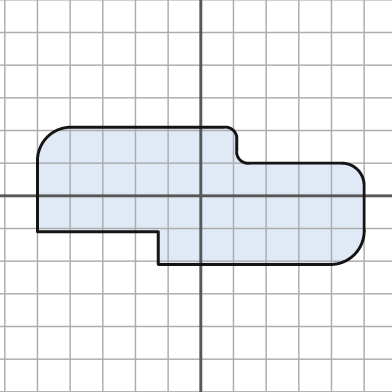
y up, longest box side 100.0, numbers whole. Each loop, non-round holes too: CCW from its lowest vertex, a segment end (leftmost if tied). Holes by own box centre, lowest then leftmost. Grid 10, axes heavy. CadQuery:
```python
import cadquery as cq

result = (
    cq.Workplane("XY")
    .moveTo(-13.0, -21.0)
    .lineTo(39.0, -21.0)
    .threePointArc((47.0, -18.0), (50.0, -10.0))
    .lineTo(50.0, 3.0)
    .threePointArc((48.0, 8.0), (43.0, 10.0))
    .lineTo(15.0, 10.0)
    .threePointArc((12.0, 11.0), (11.0, 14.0))
    .lineTo(11.0, 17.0)
    .threePointArc((10.0, 20.0), (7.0, 21.0))
    .lineTo(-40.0, 21.0)
    .threePointArc((-47.0, 18.0), (-50.0, 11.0))
    .lineTo(-50.0, -11.0)
    .lineTo(-13.0, -11.0)
    .close()
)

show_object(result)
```